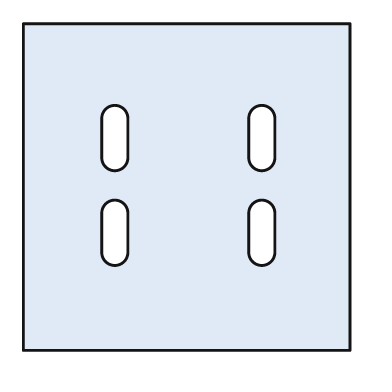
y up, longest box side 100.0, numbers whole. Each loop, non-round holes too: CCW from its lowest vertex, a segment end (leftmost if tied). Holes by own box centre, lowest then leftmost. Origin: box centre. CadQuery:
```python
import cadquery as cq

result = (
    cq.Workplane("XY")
    .moveTo(-50.0, -50.0)
    .lineTo(50.0, -50.0)
    .lineTo(50.0, 50.0)
    .lineTo(-50.0, 50.0)
    .close()
    .moveTo(-26.0, -20.0)
    .threePointArc((-22.0, -24.0), (-18.0, -20.0))
    .lineTo(-18.0, -8.0)
    .threePointArc((-22.0, -4.0), (-26.0, -8.0))
    .close()
    .moveTo(19.0, -20.0)
    .threePointArc((23.0, -24.0), (27.0, -20.0))
    .lineTo(27.0, -8.0)
    .threePointArc((23.0, -4.0), (19.0, -8.0))
    .close()
    .moveTo(-26.0, 9.0)
    .threePointArc((-22.0, 5.0), (-18.0, 9.0))
    .lineTo(-18.0, 21.0)
    .threePointArc((-22.0, 25.0), (-26.0, 21.0))
    .close()
    .moveTo(19.0, 9.0)
    .threePointArc((23.0, 5.0), (27.0, 9.0))
    .lineTo(27.0, 21.0)
    .threePointArc((23.0, 25.0), (19.0, 21.0))
    .close()
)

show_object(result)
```